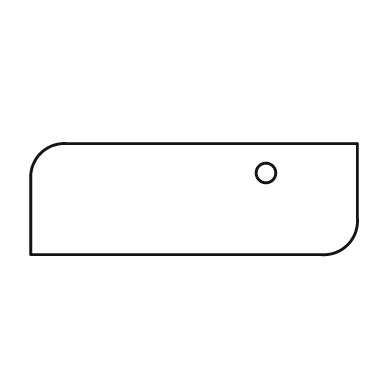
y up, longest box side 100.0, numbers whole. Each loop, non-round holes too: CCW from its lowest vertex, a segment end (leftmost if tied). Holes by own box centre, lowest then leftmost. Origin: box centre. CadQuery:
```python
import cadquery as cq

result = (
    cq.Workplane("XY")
    .moveTo(-50.0, -17.0)
    .lineTo(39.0, -17.0)
    .threePointArc((47.0, -14.0), (50.0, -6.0))
    .lineTo(50.0, 17.0)
    .lineTo(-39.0, 17.0)
    .threePointArc((-47.0, 14.0), (-50.0, 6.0))
    .close()
    .moveTo(22.0, 8.0)
    .circle(3.0)
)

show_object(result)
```